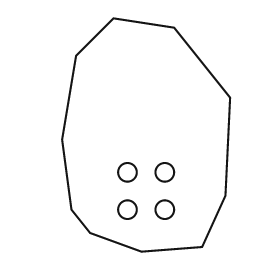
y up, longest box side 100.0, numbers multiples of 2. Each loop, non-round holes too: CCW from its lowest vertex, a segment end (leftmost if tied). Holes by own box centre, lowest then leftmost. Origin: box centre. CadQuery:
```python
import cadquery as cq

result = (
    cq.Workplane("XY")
    .moveTo(-2.0, -50.0)
    .lineTo(24.0, -48.0)
    .lineTo(34.0, -26.0)
    .lineTo(36.0, 16.0)
    .lineTo(12.0, 46.0)
    .lineTo(-14.0, 50.0)
    .lineTo(-30.0, 34.0)
    .lineTo(-36.0, -2.0)
    .lineTo(-32.0, -32.0)
    .lineTo(-24.0, -42.0)
    .close()
    .moveTo(-8.0, -32.0)
    .circle(4.0)
    .moveTo(8.0, -32.0)
    .circle(4.0)
    .moveTo(-8.0, -16.0)
    .circle(4.0)
    .moveTo(8.0, -16.0)
    .circle(4.0)
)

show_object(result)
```